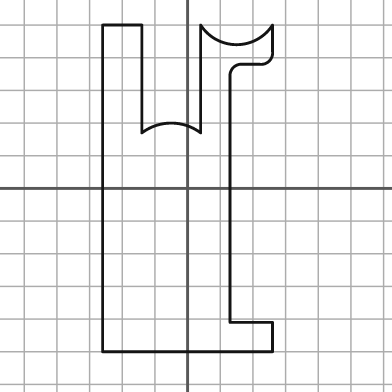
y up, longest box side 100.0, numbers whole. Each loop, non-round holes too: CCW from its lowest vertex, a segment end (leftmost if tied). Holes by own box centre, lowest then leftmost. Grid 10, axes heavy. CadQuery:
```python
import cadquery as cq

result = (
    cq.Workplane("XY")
    .moveTo(-26.0, -50.0)
    .lineTo(26.0, -50.0)
    .lineTo(26.0, -41.0)
    .lineTo(13.0, -41.0)
    .lineTo(13.0, 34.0)
    .threePointArc((14.0, 37.0), (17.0, 38.0))
    .lineTo(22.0, 38.0)
    .threePointArc((25.0, 39.0), (26.0, 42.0))
    .lineTo(26.0, 50.0)
    .threePointArc((15.0, 44.0), (4.0, 50.0))
    .lineTo(4.0, 17.0)
    .threePointArc((-5.0, 20.0), (-14.0, 17.0))
    .lineTo(-14.0, 50.0)
    .lineTo(-26.0, 50.0)
    .close()
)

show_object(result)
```